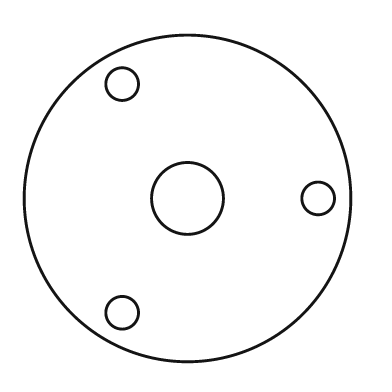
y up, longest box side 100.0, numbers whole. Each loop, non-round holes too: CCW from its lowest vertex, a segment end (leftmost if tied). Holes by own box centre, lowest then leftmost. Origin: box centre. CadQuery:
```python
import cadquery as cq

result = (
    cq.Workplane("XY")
    .moveTo(0.0, 0.0)
    .circle(50.0)
    .moveTo(-20.0, -35.0)
    .circle(5.0)
    .moveTo(0.0, 0.0)
    .circle(11.0)
    .moveTo(40.0, 0.0)
    .circle(5.0)
    .moveTo(-20.0, 35.0)
    .circle(5.0)
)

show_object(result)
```